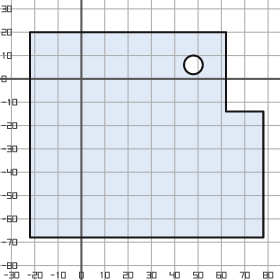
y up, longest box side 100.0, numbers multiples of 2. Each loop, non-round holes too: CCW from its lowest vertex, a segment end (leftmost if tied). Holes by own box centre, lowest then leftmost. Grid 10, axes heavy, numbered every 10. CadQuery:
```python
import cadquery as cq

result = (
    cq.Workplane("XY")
    .moveTo(-22.0, -68.0)
    .lineTo(78.0, -68.0)
    .lineTo(78.0, -14.0)
    .lineTo(62.0, -14.0)
    .lineTo(62.0, 20.0)
    .lineTo(-22.0, 20.0)
    .close()
    .moveTo(48.0, 6.0)
    .circle(4.0)
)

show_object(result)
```